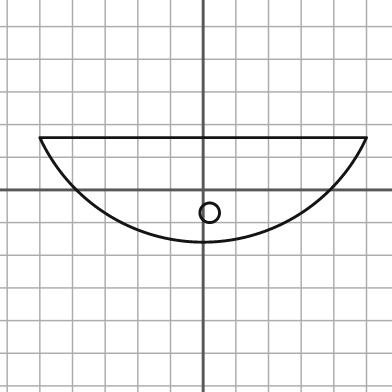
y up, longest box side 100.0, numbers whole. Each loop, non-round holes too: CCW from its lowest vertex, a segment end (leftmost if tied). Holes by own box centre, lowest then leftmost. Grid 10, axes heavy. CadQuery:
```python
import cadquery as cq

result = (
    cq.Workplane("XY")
    .moveTo(-50.0, 16.0)
    .threePointArc((0.0, -16.0), (50.0, 16.0))
    .close()
    .moveTo(2.0, -7.0)
    .circle(3.0)
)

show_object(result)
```